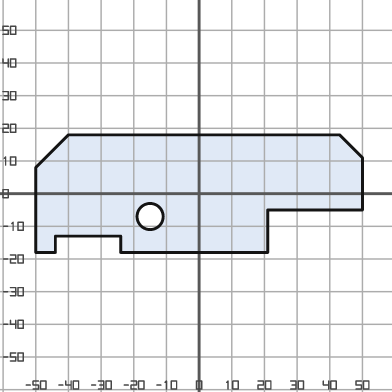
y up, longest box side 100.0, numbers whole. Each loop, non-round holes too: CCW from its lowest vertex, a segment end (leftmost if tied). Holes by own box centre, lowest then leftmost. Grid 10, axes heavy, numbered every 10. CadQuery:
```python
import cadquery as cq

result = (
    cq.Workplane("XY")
    .moveTo(-50.0, -18.0)
    .lineTo(-44.0, -18.0)
    .lineTo(-44.0, -13.0)
    .lineTo(-24.0, -13.0)
    .lineTo(-24.0, -18.0)
    .lineTo(21.0, -18.0)
    .lineTo(21.0, -5.0)
    .lineTo(50.0, -5.0)
    .lineTo(50.0, 11.0)
    .lineTo(43.0, 18.0)
    .lineTo(-40.0, 18.0)
    .lineTo(-50.0, 8.0)
    .close()
    .moveTo(-15.0, -7.0)
    .circle(4.0)
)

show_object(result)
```